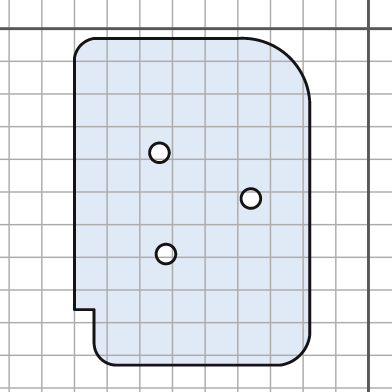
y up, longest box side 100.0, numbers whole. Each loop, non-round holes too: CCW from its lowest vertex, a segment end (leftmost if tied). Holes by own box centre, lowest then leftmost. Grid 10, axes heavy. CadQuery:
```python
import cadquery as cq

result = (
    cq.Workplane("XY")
    .moveTo(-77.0, -103.0)
    .lineTo(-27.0, -103.0)
    .threePointArc((-21.0, -100.0), (-18.0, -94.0))
    .lineTo(-18.0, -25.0)
    .threePointArc((-24.0, -9.0), (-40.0, -3.0))
    .lineTo(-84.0, -3.0)
    .threePointArc((-88.0, -5.0), (-90.0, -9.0))
    .lineTo(-90.0, -86.0)
    .lineTo(-84.0, -86.0)
    .lineTo(-84.0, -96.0)
    .threePointArc((-82.0, -101.0), (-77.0, -103.0))
    .close()
    .moveTo(-62.0, -69.0)
    .circle(3.0)
    .moveTo(-36.0, -52.0)
    .circle(3.0)
    .moveTo(-64.0, -38.0)
    .circle(3.0)
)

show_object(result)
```